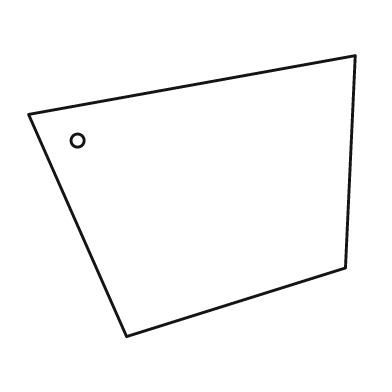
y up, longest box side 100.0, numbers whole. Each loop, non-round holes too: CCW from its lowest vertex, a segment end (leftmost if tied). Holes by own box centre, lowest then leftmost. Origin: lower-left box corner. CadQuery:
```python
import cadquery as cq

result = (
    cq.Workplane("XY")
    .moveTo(30.0, 0.0)
    .lineTo(97.0, 21.0)
    .lineTo(100.0, 86.0)
    .lineTo(0.0, 68.0)
    .close()
    .moveTo(15.0, 60.0)
    .circle(2.0)
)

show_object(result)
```